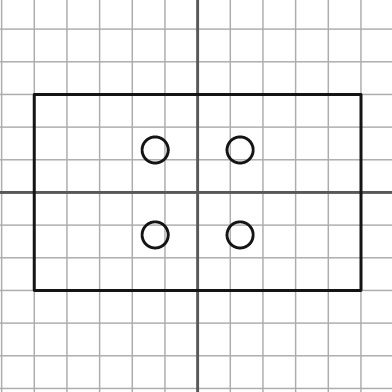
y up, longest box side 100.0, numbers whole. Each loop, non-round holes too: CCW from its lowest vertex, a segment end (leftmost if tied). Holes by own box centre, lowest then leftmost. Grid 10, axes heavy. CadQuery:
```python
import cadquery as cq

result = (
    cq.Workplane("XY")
    .moveTo(-50.0, -30.0)
    .lineTo(50.0, -30.0)
    .lineTo(50.0, 30.0)
    .lineTo(-50.0, 30.0)
    .close()
    .moveTo(-13.0, -13.0)
    .circle(4.0)
    .moveTo(13.0, -13.0)
    .circle(4.0)
    .moveTo(-13.0, 13.0)
    .circle(4.0)
    .moveTo(13.0, 13.0)
    .circle(4.0)
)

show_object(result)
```